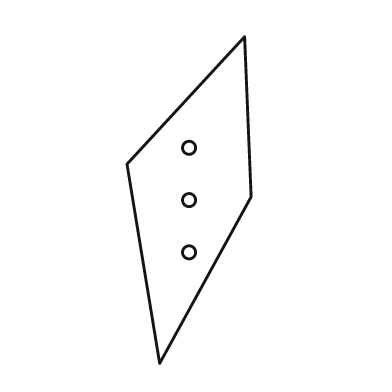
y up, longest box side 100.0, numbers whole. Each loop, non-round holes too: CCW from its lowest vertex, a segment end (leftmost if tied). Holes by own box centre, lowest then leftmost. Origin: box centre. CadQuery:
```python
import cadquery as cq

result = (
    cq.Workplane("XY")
    .moveTo(-9.0, -50.0)
    .lineTo(19.0, 1.0)
    .lineTo(17.0, 50.0)
    .lineTo(-19.0, 11.0)
    .close()
    .moveTo(0.0, -16.0)
    .circle(2.0)
    .moveTo(0.0, 0.0)
    .circle(2.0)
    .moveTo(0.0, 16.0)
    .circle(2.0)
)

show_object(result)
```